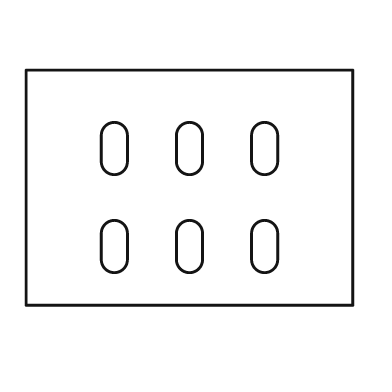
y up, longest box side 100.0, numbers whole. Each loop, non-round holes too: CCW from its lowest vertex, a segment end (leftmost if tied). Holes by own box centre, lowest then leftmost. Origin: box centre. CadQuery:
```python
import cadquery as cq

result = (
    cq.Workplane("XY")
    .moveTo(-50.0, -36.0)
    .lineTo(50.0, -36.0)
    .lineTo(50.0, 36.0)
    .lineTo(-50.0, 36.0)
    .close()
    .moveTo(-27.0, -22.0)
    .threePointArc((-23.0, -26.0), (-19.0, -22.0))
    .lineTo(-19.0, -14.0)
    .threePointArc((-23.0, -10.0), (-27.0, -14.0))
    .close()
    .moveTo(-4.0, -22.0)
    .threePointArc((0.0, -26.0), (4.0, -22.0))
    .lineTo(4.0, -14.0)
    .threePointArc((0.0, -10.0), (-4.0, -14.0))
    .close()
    .moveTo(19.0, -22.0)
    .threePointArc((23.0, -26.0), (27.0, -22.0))
    .lineTo(27.0, -14.0)
    .threePointArc((23.0, -10.0), (19.0, -14.0))
    .close()
    .moveTo(-27.0, 8.0)
    .threePointArc((-23.0, 4.0), (-19.0, 8.0))
    .lineTo(-19.0, 16.0)
    .threePointArc((-23.0, 20.0), (-27.0, 16.0))
    .close()
    .moveTo(-4.0, 8.0)
    .threePointArc((0.0, 4.0), (4.0, 8.0))
    .lineTo(4.0, 16.0)
    .threePointArc((0.0, 20.0), (-4.0, 16.0))
    .close()
    .moveTo(19.0, 8.0)
    .threePointArc((23.0, 4.0), (27.0, 8.0))
    .lineTo(27.0, 16.0)
    .threePointArc((23.0, 20.0), (19.0, 16.0))
    .close()
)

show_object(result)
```